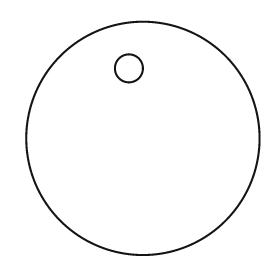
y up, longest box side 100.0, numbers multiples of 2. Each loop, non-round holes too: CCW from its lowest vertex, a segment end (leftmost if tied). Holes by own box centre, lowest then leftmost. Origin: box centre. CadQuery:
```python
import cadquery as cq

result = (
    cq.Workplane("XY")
    .moveTo(0.0, 0.0)
    .circle(50.0)
    .moveTo(-6.0, 30.0)
    .circle(6.0)
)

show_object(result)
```